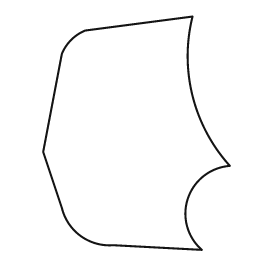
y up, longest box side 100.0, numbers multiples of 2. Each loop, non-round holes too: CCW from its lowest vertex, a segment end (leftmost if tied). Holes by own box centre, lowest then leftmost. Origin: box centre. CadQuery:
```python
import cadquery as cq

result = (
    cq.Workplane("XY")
    .moveTo(28.0, -50.0)
    .threePointArc((22.0, -28.0), (40.0, -14.0))
    .threePointArc((24.0, 16.0), (24.0, 50.0))
    .lineTo(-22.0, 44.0)
    .threePointArc((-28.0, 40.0), (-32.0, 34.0))
    .lineTo(-40.0, -8.0)
    .lineTo(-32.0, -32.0)
    .threePointArc((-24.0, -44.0), (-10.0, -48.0))
    .close()
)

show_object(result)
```